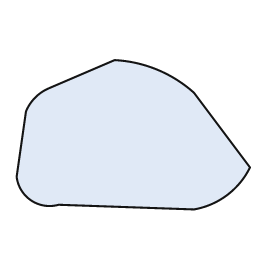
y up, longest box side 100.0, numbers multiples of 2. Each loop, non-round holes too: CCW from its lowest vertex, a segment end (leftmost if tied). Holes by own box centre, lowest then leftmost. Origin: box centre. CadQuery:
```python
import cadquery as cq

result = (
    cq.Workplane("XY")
    .moveTo(26.0, -32.0)
    .threePointArc((40.0, -26.0), (50.0, -14.0))
    .lineTo(26.0, 18.0)
    .threePointArc((10.0, 28.0), (-8.0, 32.0))
    .lineTo(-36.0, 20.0)
    .threePointArc((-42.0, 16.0), (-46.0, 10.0))
    .lineTo(-50.0, -18.0)
    .threePointArc((-44.0, -28.0), (-32.0, -30.0))
    .close()
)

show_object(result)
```